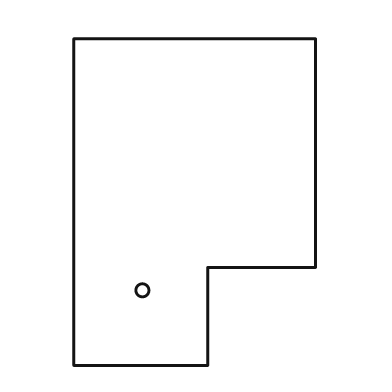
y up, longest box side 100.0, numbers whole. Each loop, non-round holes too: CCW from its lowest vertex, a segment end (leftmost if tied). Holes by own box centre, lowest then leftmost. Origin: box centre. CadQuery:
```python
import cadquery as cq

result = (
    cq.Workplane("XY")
    .moveTo(-37.0, -50.0)
    .lineTo(4.0, -50.0)
    .lineTo(4.0, -20.0)
    .lineTo(37.0, -20.0)
    .lineTo(37.0, 50.0)
    .lineTo(-37.0, 50.0)
    .close()
    .moveTo(-16.0, -27.0)
    .circle(2.0)
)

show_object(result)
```